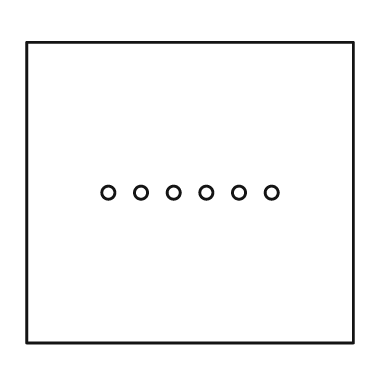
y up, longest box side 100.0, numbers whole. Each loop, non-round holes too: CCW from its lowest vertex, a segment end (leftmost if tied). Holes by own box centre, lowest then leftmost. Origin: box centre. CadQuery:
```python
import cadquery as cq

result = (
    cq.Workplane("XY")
    .moveTo(-50.0, -46.0)
    .lineTo(50.0, -46.0)
    .lineTo(50.0, 46.0)
    .lineTo(-50.0, 46.0)
    .close()
    .moveTo(-25.0, 0.0)
    .circle(2.0)
    .moveTo(-15.0, 0.0)
    .circle(2.0)
    .moveTo(-5.0, 0.0)
    .circle(2.0)
    .moveTo(5.0, 0.0)
    .circle(2.0)
    .moveTo(15.0, 0.0)
    .circle(2.0)
    .moveTo(25.0, 0.0)
    .circle(2.0)
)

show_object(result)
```